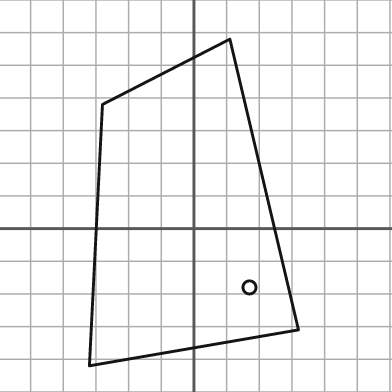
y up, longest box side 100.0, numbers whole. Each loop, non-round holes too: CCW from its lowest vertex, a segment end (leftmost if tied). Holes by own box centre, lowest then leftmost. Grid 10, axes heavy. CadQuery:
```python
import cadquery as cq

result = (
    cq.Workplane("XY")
    .moveTo(-32.0, -42.0)
    .lineTo(32.0, -31.0)
    .lineTo(11.0, 58.0)
    .lineTo(-28.0, 38.0)
    .close()
    .moveTo(17.0, -18.0)
    .circle(2.0)
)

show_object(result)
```